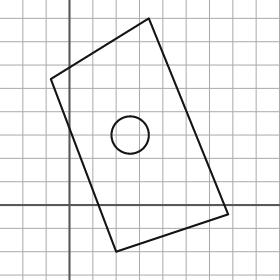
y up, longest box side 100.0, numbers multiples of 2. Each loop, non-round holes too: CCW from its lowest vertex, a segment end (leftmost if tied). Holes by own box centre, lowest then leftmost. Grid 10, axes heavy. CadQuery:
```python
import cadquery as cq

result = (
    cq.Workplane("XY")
    .moveTo(20.0, -20.0)
    .lineTo(68.0, -4.0)
    .lineTo(34.0, 80.0)
    .lineTo(-8.0, 54.0)
    .close()
    .moveTo(26.0, 30.0)
    .circle(8.0)
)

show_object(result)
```